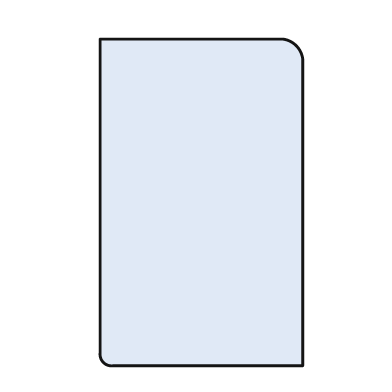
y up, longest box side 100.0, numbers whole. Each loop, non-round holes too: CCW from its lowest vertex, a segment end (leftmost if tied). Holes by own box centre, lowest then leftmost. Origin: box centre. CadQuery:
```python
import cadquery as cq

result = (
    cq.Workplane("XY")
    .moveTo(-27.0, -50.0)
    .lineTo(31.0, -50.0)
    .lineTo(31.0, 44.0)
    .threePointArc((29.0, 48.0), (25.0, 50.0))
    .lineTo(-31.0, 50.0)
    .lineTo(-31.0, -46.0)
    .threePointArc((-30.0, -49.0), (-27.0, -50.0))
    .close()
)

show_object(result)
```